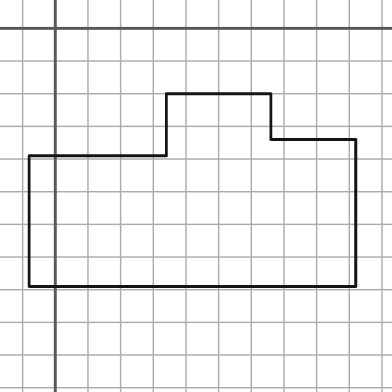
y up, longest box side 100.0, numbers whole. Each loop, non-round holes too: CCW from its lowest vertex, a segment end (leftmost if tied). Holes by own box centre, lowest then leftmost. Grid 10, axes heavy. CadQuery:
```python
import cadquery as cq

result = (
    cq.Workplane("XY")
    .moveTo(-8.0, -79.0)
    .lineTo(92.0, -79.0)
    .lineTo(92.0, -34.0)
    .lineTo(66.0, -34.0)
    .lineTo(66.0, -20.0)
    .lineTo(34.0, -20.0)
    .lineTo(34.0, -39.0)
    .lineTo(-8.0, -39.0)
    .close()
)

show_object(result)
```